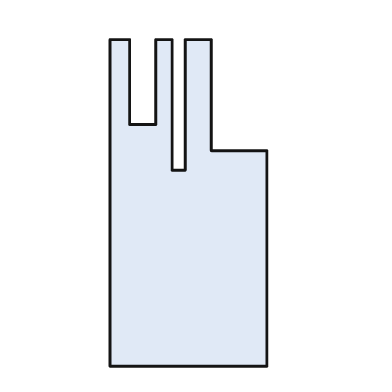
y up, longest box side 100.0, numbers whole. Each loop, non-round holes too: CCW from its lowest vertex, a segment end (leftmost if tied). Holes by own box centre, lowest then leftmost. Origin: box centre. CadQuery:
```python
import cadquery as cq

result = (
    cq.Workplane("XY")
    .moveTo(-24.0, -50.0)
    .lineTo(24.0, -50.0)
    .lineTo(24.0, 16.0)
    .lineTo(7.0, 16.0)
    .lineTo(7.0, 50.0)
    .lineTo(-1.0, 50.0)
    .lineTo(-1.0, 10.0)
    .lineTo(-5.0, 10.0)
    .lineTo(-5.0, 50.0)
    .lineTo(-10.0, 50.0)
    .lineTo(-10.0, 24.0)
    .lineTo(-18.0, 24.0)
    .lineTo(-18.0, 50.0)
    .lineTo(-24.0, 50.0)
    .close()
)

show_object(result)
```